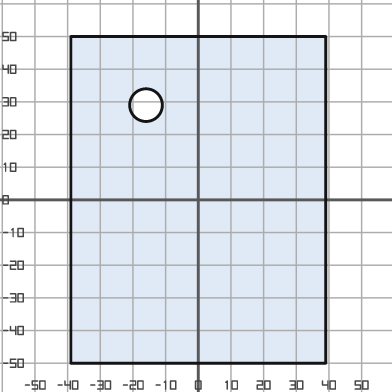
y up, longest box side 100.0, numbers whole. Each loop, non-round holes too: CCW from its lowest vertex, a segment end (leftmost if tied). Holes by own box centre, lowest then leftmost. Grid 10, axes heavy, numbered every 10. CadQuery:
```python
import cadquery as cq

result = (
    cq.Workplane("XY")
    .moveTo(-39.0, -50.0)
    .lineTo(39.0, -50.0)
    .lineTo(39.0, 50.0)
    .lineTo(-39.0, 50.0)
    .close()
    .moveTo(-16.0, 29.0)
    .circle(5.0)
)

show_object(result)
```